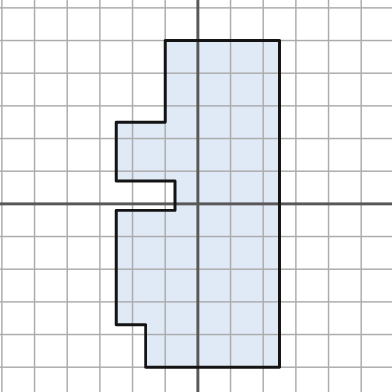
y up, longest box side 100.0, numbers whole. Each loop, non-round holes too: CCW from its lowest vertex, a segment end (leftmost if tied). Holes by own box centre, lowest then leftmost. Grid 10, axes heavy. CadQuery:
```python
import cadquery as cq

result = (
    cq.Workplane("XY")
    .moveTo(-16.0, -50.0)
    .lineTo(25.0, -50.0)
    .lineTo(25.0, 50.0)
    .lineTo(-10.0, 50.0)
    .lineTo(-10.0, 25.0)
    .lineTo(-25.0, 25.0)
    .lineTo(-25.0, 7.0)
    .lineTo(-7.0, 7.0)
    .lineTo(-7.0, -2.0)
    .lineTo(-25.0, -2.0)
    .lineTo(-25.0, -37.0)
    .lineTo(-16.0, -37.0)
    .close()
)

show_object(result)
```